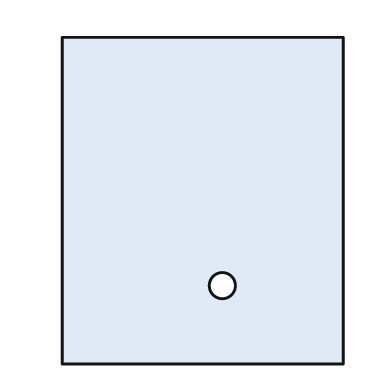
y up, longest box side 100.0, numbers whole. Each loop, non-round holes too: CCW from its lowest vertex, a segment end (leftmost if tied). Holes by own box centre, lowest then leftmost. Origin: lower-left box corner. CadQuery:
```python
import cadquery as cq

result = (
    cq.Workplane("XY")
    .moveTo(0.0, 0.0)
    .lineTo(86.0, 0.0)
    .lineTo(86.0, 100.0)
    .lineTo(0.0, 100.0)
    .close()
    .moveTo(49.0, 24.0)
    .circle(4.0)
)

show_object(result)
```